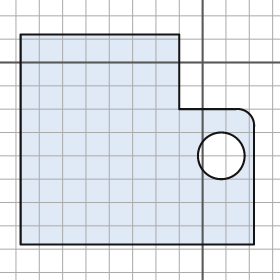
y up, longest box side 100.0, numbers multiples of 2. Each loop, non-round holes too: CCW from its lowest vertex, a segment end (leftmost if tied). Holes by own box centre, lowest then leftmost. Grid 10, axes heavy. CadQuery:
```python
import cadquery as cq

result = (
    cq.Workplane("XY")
    .moveTo(-78.0, -78.0)
    .lineTo(22.0, -78.0)
    .lineTo(22.0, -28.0)
    .threePointArc((20.0, -22.0), (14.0, -20.0))
    .lineTo(-10.0, -20.0)
    .lineTo(-10.0, 12.0)
    .lineTo(-78.0, 12.0)
    .close()
    .moveTo(8.0, -40.0)
    .circle(10.0)
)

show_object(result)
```